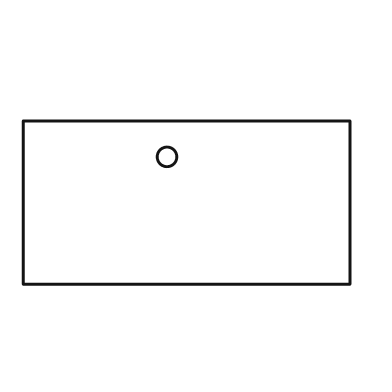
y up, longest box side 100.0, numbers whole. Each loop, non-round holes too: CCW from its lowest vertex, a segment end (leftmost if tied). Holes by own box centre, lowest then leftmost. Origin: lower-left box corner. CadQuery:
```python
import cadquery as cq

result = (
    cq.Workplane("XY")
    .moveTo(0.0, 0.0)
    .lineTo(100.0, 0.0)
    .lineTo(100.0, 50.0)
    .lineTo(0.0, 50.0)
    .close()
    .moveTo(44.0, 39.0)
    .circle(3.0)
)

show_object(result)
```